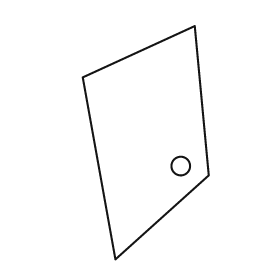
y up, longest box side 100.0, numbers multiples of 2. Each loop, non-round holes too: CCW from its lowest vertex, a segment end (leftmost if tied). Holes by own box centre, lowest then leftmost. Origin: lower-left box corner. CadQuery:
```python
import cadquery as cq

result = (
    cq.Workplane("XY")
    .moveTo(14.0, 0.0)
    .lineTo(54.0, 36.0)
    .lineTo(48.0, 100.0)
    .lineTo(0.0, 78.0)
    .close()
    .moveTo(42.0, 40.0)
    .circle(4.0)
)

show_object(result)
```